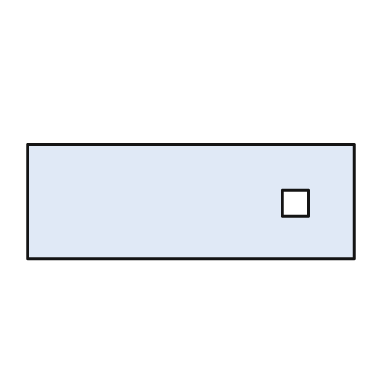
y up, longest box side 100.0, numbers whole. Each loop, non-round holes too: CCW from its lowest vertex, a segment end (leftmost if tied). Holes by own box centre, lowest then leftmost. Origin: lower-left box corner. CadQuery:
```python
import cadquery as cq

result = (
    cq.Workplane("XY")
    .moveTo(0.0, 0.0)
    .lineTo(100.0, 0.0)
    .lineTo(100.0, 35.0)
    .lineTo(0.0, 35.0)
    .close()
    .moveTo(78.0, 13.0)
    .lineTo(86.0, 13.0)
    .lineTo(86.0, 21.0)
    .lineTo(78.0, 21.0)
    .close()
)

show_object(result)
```